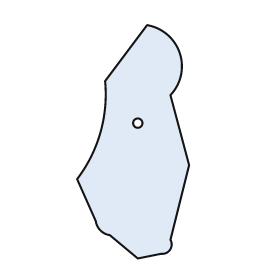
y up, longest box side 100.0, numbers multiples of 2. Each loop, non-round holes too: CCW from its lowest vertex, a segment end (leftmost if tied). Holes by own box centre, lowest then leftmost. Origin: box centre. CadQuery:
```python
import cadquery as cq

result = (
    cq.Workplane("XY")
    .moveTo(2.0, -50.0)
    .lineTo(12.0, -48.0)
    .threePointArc((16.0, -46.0), (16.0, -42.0))
    .lineTo(24.0, -10.0)
    .lineTo(16.0, 20.0)
    .threePointArc((20.0, 38.0), (6.0, 50.0))
    .lineTo(-12.0, 26.0)
    .threePointArc((-14.0, 4.0), (-24.0, -16.0))
    .lineTo(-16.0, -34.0)
    .threePointArc((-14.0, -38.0), (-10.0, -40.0))
    .close()
    .moveTo(2.0, 8.0)
    .circle(2.0)
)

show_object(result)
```